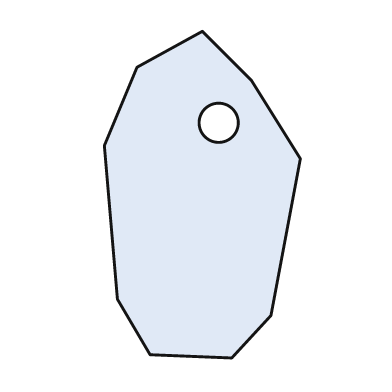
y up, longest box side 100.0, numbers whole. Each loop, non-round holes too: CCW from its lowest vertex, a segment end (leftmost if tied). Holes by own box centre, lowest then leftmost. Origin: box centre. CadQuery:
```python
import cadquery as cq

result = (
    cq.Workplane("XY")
    .moveTo(9.0, -50.0)
    .lineTo(21.0, -37.0)
    .lineTo(30.0, 11.0)
    .lineTo(15.0, 35.0)
    .lineTo(0.0, 50.0)
    .lineTo(-20.0, 39.0)
    .lineTo(-30.0, 15.0)
    .lineTo(-26.0, -32.0)
    .lineTo(-16.0, -49.0)
    .close()
    .moveTo(5.0, 22.0)
    .circle(6.0)
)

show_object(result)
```